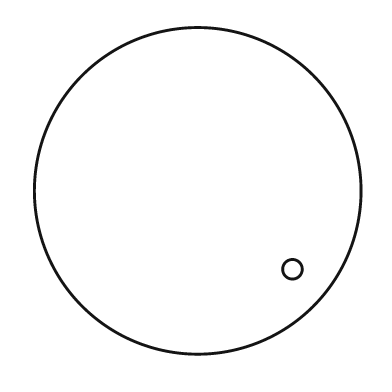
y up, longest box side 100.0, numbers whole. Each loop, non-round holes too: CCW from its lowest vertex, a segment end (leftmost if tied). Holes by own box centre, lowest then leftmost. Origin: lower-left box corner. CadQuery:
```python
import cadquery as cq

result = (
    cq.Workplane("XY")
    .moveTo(50.0, 50.0)
    .circle(50.0)
    .moveTo(79.0, 26.0)
    .circle(3.0)
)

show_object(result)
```